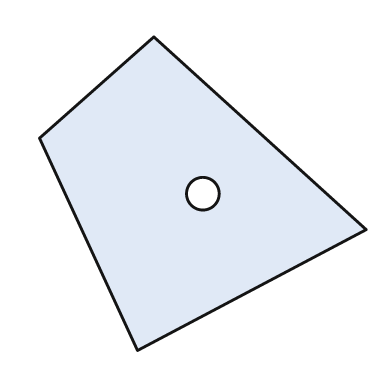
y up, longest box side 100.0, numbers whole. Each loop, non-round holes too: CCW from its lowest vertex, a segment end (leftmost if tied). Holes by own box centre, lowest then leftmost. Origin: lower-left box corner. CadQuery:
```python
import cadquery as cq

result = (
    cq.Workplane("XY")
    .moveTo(30.0, 0.0)
    .lineTo(100.0, 37.0)
    .lineTo(35.0, 96.0)
    .lineTo(0.0, 65.0)
    .close()
    .moveTo(50.0, 48.0)
    .circle(5.0)
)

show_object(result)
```